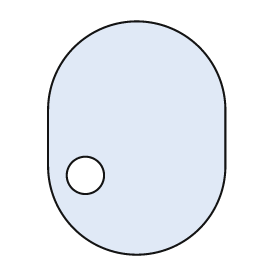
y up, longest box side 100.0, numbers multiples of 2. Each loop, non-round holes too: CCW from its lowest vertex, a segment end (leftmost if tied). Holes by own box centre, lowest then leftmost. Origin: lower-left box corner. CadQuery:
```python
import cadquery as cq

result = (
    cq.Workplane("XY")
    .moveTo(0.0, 38.0)
    .threePointArc((38.0, 0.0), (76.0, 38.0))
    .lineTo(76.0, 62.0)
    .threePointArc((38.0, 100.0), (0.0, 62.0))
    .close()
    .moveTo(16.0, 34.0)
    .circle(8.0)
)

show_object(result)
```